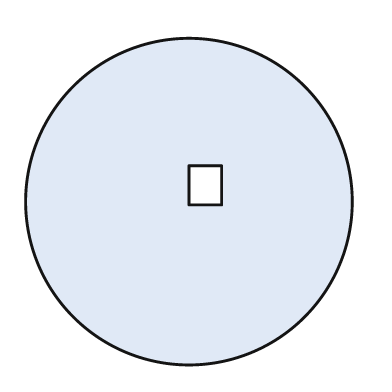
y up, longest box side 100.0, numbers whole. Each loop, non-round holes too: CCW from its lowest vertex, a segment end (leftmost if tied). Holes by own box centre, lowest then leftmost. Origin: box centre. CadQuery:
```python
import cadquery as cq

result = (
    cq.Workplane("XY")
    .moveTo(0.0, 0.0)
    .circle(50.0)
    .moveTo(0.0, -1.0)
    .lineTo(10.0, -1.0)
    .lineTo(10.0, 11.0)
    .lineTo(0.0, 11.0)
    .close()
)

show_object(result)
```